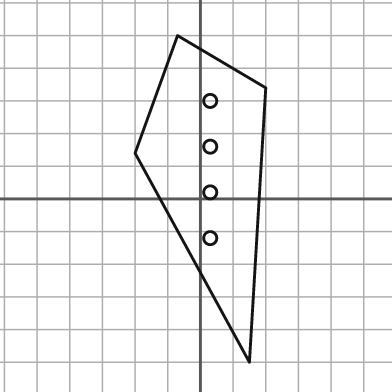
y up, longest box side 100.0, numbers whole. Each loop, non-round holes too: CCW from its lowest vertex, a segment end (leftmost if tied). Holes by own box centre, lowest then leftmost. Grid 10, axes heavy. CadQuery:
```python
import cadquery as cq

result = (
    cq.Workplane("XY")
    .moveTo(15.0, -50.0)
    .lineTo(20.0, 34.0)
    .lineTo(-7.0, 50.0)
    .lineTo(-20.0, 14.0)
    .close()
    .moveTo(3.0, -12.0)
    .circle(2.0)
    .moveTo(3.0, 2.0)
    .circle(2.0)
    .moveTo(3.0, 16.0)
    .circle(2.0)
    .moveTo(3.0, 30.0)
    .circle(2.0)
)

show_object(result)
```